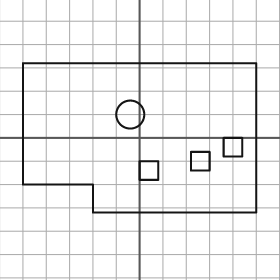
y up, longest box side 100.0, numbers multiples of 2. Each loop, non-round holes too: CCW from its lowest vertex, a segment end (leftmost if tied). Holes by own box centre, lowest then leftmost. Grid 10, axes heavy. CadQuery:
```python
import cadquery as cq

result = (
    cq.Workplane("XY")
    .moveTo(-20.0, -32.0)
    .lineTo(50.0, -32.0)
    .lineTo(50.0, 32.0)
    .lineTo(-50.0, 32.0)
    .lineTo(-50.0, -20.0)
    .lineTo(-20.0, -20.0)
    .close()
    .moveTo(0.0, -18.0)
    .lineTo(8.0, -18.0)
    .lineTo(8.0, -10.0)
    .lineTo(0.0, -10.0)
    .close()
    .moveTo(22.0, -14.0)
    .lineTo(30.0, -14.0)
    .lineTo(30.0, -6.0)
    .lineTo(22.0, -6.0)
    .close()
    .moveTo(36.0, -8.0)
    .lineTo(44.0, -8.0)
    .lineTo(44.0, 0.0)
    .lineTo(36.0, 0.0)
    .close()
    .moveTo(-4.0, 10.0)
    .circle(6.0)
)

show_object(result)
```